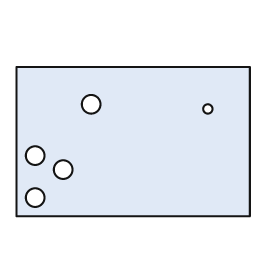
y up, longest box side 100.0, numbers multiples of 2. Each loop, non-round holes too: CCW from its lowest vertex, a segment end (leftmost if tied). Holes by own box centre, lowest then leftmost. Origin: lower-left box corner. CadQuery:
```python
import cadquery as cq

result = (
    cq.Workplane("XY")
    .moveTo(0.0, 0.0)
    .lineTo(100.0, 0.0)
    .lineTo(100.0, 64.0)
    .lineTo(0.0, 64.0)
    .close()
    .moveTo(8.0, 8.0)
    .circle(4.0)
    .moveTo(20.0, 20.0)
    .circle(4.0)
    .moveTo(8.0, 26.0)
    .circle(4.0)
    .moveTo(82.0, 46.0)
    .circle(2.0)
    .moveTo(32.0, 48.0)
    .circle(4.0)
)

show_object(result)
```